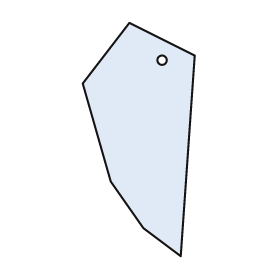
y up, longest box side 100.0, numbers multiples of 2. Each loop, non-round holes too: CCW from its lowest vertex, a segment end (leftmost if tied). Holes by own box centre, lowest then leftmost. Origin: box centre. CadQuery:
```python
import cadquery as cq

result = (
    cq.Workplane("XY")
    .moveTo(18.0, -50.0)
    .lineTo(24.0, 36.0)
    .lineTo(-4.0, 50.0)
    .lineTo(-24.0, 24.0)
    .lineTo(-12.0, -18.0)
    .lineTo(2.0, -38.0)
    .close()
    .moveTo(10.0, 34.0)
    .circle(2.0)
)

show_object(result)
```